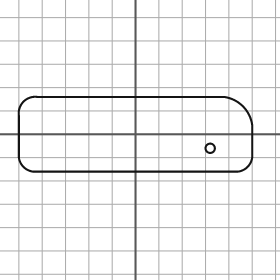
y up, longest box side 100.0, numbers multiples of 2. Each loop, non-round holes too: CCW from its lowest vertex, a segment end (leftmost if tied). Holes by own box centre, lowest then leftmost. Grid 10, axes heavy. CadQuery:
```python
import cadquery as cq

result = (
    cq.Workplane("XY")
    .moveTo(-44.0, -16.0)
    .lineTo(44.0, -16.0)
    .threePointArc((48.0, -14.0), (50.0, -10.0))
    .lineTo(50.0, 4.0)
    .threePointArc((46.0, 12.0), (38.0, 16.0))
    .lineTo(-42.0, 16.0)
    .threePointArc((-48.0, 14.0), (-50.0, 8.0))
    .lineTo(-50.0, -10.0)
    .threePointArc((-48.0, -14.0), (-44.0, -16.0))
    .close()
    .moveTo(32.0, -6.0)
    .circle(2.0)
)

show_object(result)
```